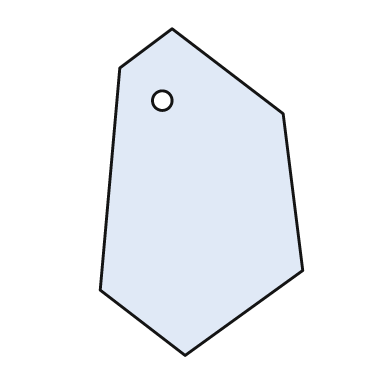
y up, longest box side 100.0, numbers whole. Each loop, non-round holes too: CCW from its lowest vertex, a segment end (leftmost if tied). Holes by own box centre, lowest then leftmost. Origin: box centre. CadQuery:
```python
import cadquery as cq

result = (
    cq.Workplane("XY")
    .moveTo(-5.0, -50.0)
    .lineTo(31.0, -24.0)
    .lineTo(25.0, 24.0)
    .lineTo(-9.0, 50.0)
    .lineTo(-25.0, 38.0)
    .lineTo(-31.0, -30.0)
    .close()
    .moveTo(-12.0, 28.0)
    .circle(3.0)
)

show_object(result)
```